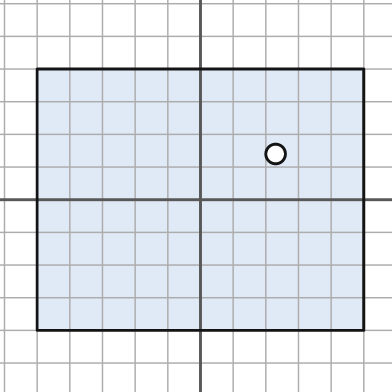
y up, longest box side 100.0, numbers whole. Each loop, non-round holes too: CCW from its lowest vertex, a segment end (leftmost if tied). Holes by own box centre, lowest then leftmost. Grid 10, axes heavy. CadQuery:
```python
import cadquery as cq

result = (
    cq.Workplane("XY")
    .moveTo(-50.0, -40.0)
    .lineTo(50.0, -40.0)
    .lineTo(50.0, 40.0)
    .lineTo(-50.0, 40.0)
    .close()
    .moveTo(23.0, 14.0)
    .circle(3.0)
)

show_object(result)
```